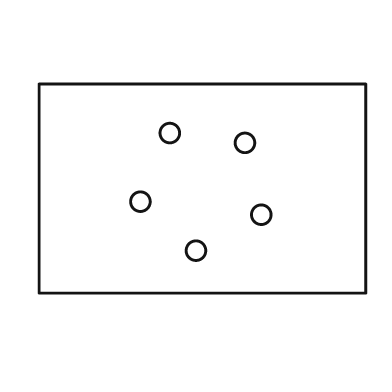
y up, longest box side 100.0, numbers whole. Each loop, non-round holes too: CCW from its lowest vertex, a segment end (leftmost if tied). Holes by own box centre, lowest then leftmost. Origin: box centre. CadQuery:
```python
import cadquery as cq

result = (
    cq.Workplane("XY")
    .moveTo(-50.0, -32.0)
    .lineTo(50.0, -32.0)
    .lineTo(50.0, 32.0)
    .lineTo(-50.0, 32.0)
    .close()
    .moveTo(-2.0, -19.0)
    .circle(3.0)
    .moveTo(18.0, -8.0)
    .circle(3.0)
    .moveTo(-19.0, -4.0)
    .circle(3.0)
    .moveTo(13.0, 14.0)
    .circle(3.0)
    .moveTo(-10.0, 17.0)
    .circle(3.0)
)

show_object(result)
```